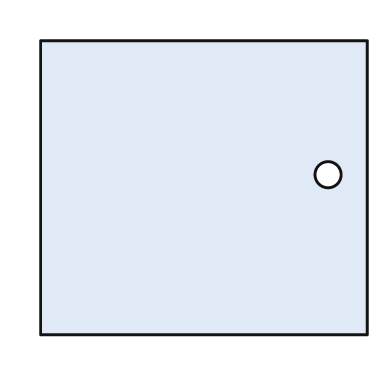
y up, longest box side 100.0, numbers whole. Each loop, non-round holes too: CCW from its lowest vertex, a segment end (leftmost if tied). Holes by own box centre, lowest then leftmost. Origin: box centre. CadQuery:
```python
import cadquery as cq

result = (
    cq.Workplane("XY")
    .moveTo(-50.0, -45.0)
    .lineTo(50.0, -45.0)
    .lineTo(50.0, 45.0)
    .lineTo(-50.0, 45.0)
    .close()
    .moveTo(38.0, 4.0)
    .circle(4.0)
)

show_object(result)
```